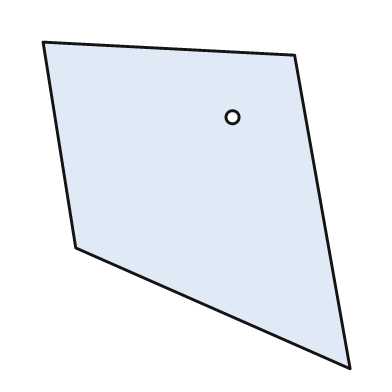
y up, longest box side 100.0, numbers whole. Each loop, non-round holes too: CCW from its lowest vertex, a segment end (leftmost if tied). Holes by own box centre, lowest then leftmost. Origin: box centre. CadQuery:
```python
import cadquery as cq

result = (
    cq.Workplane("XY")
    .moveTo(47.0, -50.0)
    .lineTo(30.0, 46.0)
    .lineTo(-47.0, 50.0)
    .lineTo(-37.0, -13.0)
    .close()
    .moveTo(11.0, 27.0)
    .circle(2.0)
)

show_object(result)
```